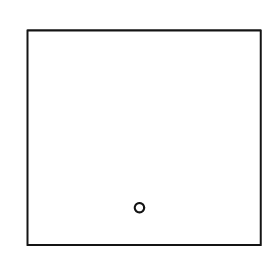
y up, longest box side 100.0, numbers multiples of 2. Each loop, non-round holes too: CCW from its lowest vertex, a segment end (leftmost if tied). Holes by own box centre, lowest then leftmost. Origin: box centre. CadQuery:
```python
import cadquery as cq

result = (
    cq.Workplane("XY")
    .moveTo(-50.0, -46.0)
    .lineTo(50.0, -46.0)
    .lineTo(50.0, 46.0)
    .lineTo(-50.0, 46.0)
    .close()
    .moveTo(-2.0, -30.0)
    .circle(2.0)
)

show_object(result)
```